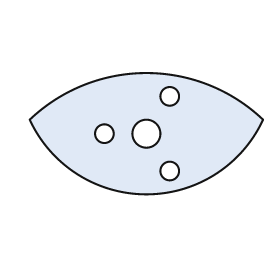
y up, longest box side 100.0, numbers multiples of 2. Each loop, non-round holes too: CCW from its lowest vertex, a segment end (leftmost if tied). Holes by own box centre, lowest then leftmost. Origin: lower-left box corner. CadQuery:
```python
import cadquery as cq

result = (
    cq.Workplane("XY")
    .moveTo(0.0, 32.0)
    .threePointArc((50.0, 0.0), (100.0, 32.0))
    .threePointArc((50.0, 52.0), (0.0, 32.0))
    .close()
    .moveTo(60.0, 10.0)
    .circle(4.0)
    .moveTo(32.0, 26.0)
    .circle(4.0)
    .moveTo(50.0, 26.0)
    .circle(6.0)
    .moveTo(60.0, 42.0)
    .circle(4.0)
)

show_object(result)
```